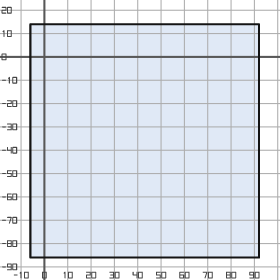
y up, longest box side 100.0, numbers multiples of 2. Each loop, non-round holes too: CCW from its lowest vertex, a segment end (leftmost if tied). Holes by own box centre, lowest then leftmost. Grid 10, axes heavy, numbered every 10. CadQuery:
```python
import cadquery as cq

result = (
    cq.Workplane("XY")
    .moveTo(-6.0, -86.0)
    .lineTo(92.0, -86.0)
    .lineTo(92.0, 14.0)
    .lineTo(-6.0, 14.0)
    .close()
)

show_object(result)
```